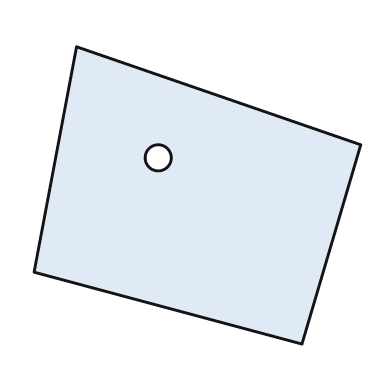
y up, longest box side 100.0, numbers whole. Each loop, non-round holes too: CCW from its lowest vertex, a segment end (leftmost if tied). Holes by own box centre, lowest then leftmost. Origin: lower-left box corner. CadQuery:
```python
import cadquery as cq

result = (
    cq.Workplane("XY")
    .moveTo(82.0, 0.0)
    .lineTo(100.0, 61.0)
    .lineTo(13.0, 91.0)
    .lineTo(0.0, 22.0)
    .close()
    .moveTo(38.0, 57.0)
    .circle(4.0)
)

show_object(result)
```